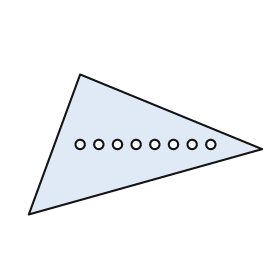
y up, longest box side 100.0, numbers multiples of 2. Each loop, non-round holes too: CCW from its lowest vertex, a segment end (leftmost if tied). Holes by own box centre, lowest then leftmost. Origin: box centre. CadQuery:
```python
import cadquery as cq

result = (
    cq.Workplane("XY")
    .moveTo(-50.0, -30.0)
    .lineTo(50.0, -2.0)
    .lineTo(-28.0, 30.0)
    .close()
    .moveTo(-28.0, 0.0)
    .circle(2.0)
    .moveTo(-20.0, 0.0)
    .circle(2.0)
    .moveTo(-12.0, 0.0)
    .circle(2.0)
    .moveTo(-4.0, 0.0)
    .circle(2.0)
    .moveTo(4.0, 0.0)
    .circle(2.0)
    .moveTo(12.0, 0.0)
    .circle(2.0)
    .moveTo(20.0, 0.0)
    .circle(2.0)
    .moveTo(28.0, 0.0)
    .circle(2.0)
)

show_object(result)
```